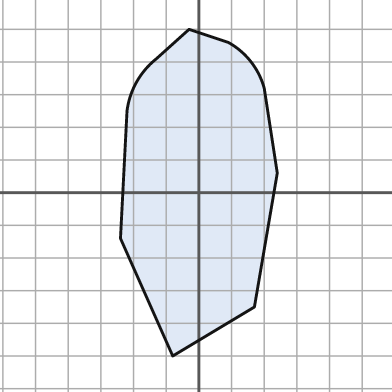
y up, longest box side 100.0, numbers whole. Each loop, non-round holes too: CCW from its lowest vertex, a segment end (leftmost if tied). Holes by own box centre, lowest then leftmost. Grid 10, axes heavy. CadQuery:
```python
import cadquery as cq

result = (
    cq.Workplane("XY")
    .moveTo(-8.0, -50.0)
    .lineTo(17.0, -35.0)
    .lineTo(24.0, 6.0)
    .lineTo(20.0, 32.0)
    .threePointArc((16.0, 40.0), (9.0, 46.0))
    .lineTo(-3.0, 50.0)
    .lineTo(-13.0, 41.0)
    .threePointArc((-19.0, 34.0), (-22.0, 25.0))
    .lineTo(-24.0, -14.0)
    .close()
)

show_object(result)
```